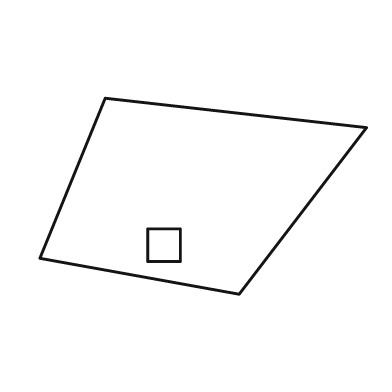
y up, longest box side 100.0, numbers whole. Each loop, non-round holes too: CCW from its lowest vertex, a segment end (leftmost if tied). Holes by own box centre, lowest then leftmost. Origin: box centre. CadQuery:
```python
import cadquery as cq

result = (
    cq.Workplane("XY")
    .moveTo(11.0, -30.0)
    .lineTo(50.0, 21.0)
    .lineTo(-30.0, 30.0)
    .lineTo(-50.0, -19.0)
    .close()
    .moveTo(-17.0, -20.0)
    .lineTo(-7.0, -20.0)
    .lineTo(-7.0, -10.0)
    .lineTo(-17.0, -10.0)
    .close()
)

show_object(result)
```